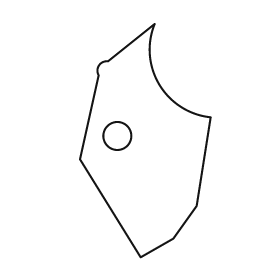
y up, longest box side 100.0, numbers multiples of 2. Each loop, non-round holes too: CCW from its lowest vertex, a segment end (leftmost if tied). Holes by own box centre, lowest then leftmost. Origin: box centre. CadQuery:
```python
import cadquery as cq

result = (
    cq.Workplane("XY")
    .moveTo(-2.0, -50.0)
    .lineTo(12.0, -42.0)
    .lineTo(22.0, -28.0)
    .lineTo(28.0, 10.0)
    .threePointArc((6.0, 24.0), (4.0, 50.0))
    .lineTo(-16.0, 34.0)
    .threePointArc((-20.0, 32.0), (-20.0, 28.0))
    .lineTo(-28.0, -8.0)
    .close()
    .moveTo(-12.0, 2.0)
    .circle(6.0)
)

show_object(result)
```